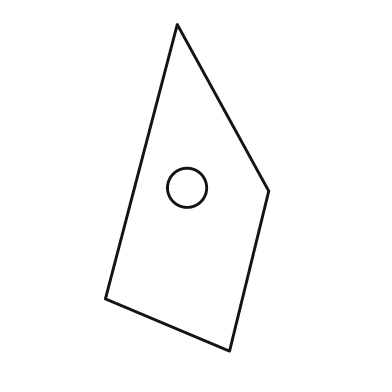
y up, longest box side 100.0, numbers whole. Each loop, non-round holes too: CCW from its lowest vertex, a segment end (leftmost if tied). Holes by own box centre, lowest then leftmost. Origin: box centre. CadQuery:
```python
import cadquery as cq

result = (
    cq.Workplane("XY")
    .moveTo(13.0, -50.0)
    .lineTo(25.0, -1.0)
    .lineTo(-3.0, 50.0)
    .lineTo(-25.0, -34.0)
    .close()
    .moveTo(0.0, 0.0)
    .circle(6.0)
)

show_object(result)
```